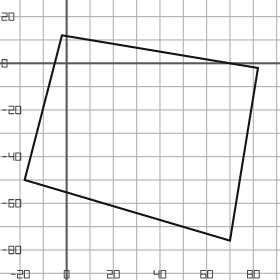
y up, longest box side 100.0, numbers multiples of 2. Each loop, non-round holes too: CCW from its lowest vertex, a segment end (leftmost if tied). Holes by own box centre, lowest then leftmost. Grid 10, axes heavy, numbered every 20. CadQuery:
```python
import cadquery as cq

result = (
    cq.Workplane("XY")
    .moveTo(70.0, -76.0)
    .lineTo(82.0, -2.0)
    .lineTo(-2.0, 12.0)
    .lineTo(-18.0, -50.0)
    .close()
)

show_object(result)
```